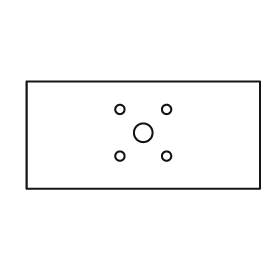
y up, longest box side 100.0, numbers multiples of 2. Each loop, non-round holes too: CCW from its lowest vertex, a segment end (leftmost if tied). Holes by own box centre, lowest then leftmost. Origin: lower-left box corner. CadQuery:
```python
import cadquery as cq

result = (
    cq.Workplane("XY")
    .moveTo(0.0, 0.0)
    .lineTo(100.0, 0.0)
    .lineTo(100.0, 46.0)
    .lineTo(0.0, 46.0)
    .close()
    .moveTo(40.0, 14.0)
    .circle(2.0)
    .moveTo(60.0, 14.0)
    .circle(2.0)
    .moveTo(50.0, 24.0)
    .circle(4.0)
    .moveTo(40.0, 34.0)
    .circle(2.0)
    .moveTo(60.0, 34.0)
    .circle(2.0)
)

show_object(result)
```